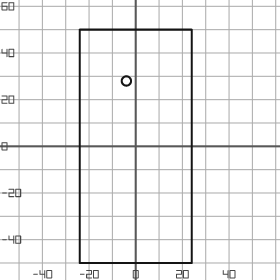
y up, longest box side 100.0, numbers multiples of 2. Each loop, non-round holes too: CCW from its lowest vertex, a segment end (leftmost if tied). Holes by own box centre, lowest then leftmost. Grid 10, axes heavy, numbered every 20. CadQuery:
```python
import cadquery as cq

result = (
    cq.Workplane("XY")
    .moveTo(-24.0, -50.0)
    .lineTo(24.0, -50.0)
    .lineTo(24.0, 50.0)
    .lineTo(-24.0, 50.0)
    .close()
    .moveTo(-4.0, 28.0)
    .circle(2.0)
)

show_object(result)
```